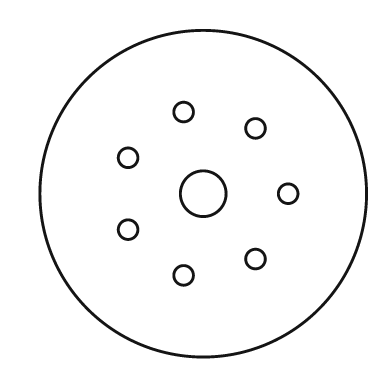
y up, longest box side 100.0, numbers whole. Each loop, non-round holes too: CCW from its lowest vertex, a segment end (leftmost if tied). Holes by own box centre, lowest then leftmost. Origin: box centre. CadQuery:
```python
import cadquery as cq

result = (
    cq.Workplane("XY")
    .moveTo(0.0, 0.0)
    .circle(50.0)
    .moveTo(-6.0, -25.0)
    .circle(3.0)
    .moveTo(16.0, -20.0)
    .circle(3.0)
    .moveTo(-23.0, -11.0)
    .circle(3.0)
    .moveTo(0.0, 0.0)
    .circle(7.0)
    .moveTo(26.0, 0.0)
    .circle(3.0)
    .moveTo(-23.0, 11.0)
    .circle(3.0)
    .moveTo(16.0, 20.0)
    .circle(3.0)
    .moveTo(-6.0, 25.0)
    .circle(3.0)
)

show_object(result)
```